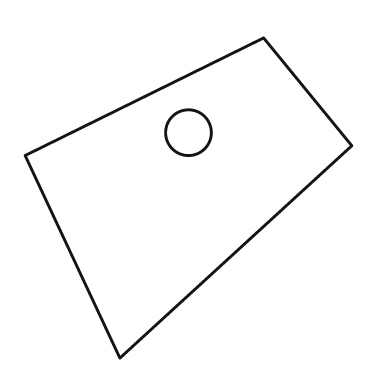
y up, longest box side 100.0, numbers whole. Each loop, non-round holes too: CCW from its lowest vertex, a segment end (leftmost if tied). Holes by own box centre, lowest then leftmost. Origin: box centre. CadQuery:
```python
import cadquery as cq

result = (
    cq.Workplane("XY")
    .moveTo(-21.0, -49.0)
    .lineTo(50.0, 16.0)
    .lineTo(23.0, 49.0)
    .lineTo(-50.0, 13.0)
    .close()
    .moveTo(0.0, 20.0)
    .circle(7.0)
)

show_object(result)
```